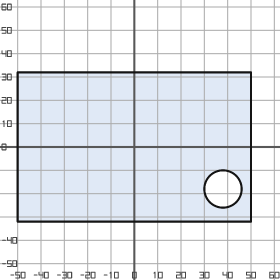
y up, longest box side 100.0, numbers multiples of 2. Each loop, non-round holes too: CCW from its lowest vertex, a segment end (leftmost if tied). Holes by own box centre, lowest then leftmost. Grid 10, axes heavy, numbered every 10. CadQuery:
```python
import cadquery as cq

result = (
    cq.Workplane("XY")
    .moveTo(-50.0, -32.0)
    .lineTo(50.0, -32.0)
    .lineTo(50.0, 32.0)
    .lineTo(-50.0, 32.0)
    .close()
    .moveTo(38.0, -18.0)
    .circle(8.0)
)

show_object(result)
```